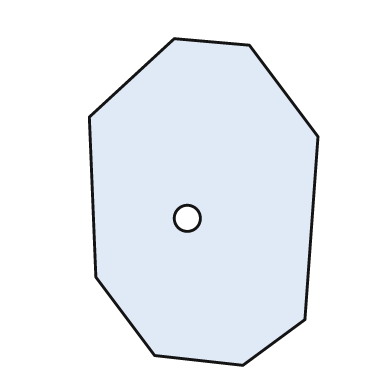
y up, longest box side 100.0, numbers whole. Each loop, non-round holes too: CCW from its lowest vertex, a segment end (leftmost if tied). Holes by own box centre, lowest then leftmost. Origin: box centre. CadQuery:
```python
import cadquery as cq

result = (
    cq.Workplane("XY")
    .moveTo(12.0, -50.0)
    .lineTo(31.0, -36.0)
    .lineTo(35.0, 20.0)
    .lineTo(14.0, 48.0)
    .lineTo(-9.0, 50.0)
    .lineTo(-35.0, 26.0)
    .lineTo(-33.0, -23.0)
    .lineTo(-15.0, -47.0)
    .close()
    .moveTo(-5.0, -5.0)
    .circle(4.0)
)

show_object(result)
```